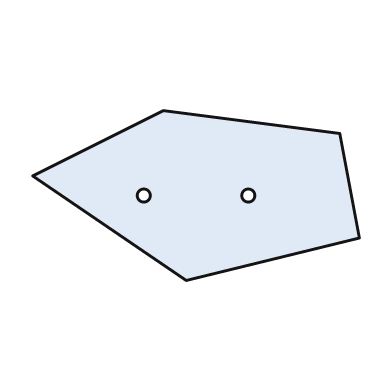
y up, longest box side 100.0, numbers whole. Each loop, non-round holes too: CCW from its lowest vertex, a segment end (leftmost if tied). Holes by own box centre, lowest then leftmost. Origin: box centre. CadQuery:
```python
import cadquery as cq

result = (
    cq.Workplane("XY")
    .moveTo(-3.0, -26.0)
    .lineTo(50.0, -13.0)
    .lineTo(44.0, 19.0)
    .lineTo(-10.0, 26.0)
    .lineTo(-50.0, 6.0)
    .close()
    .moveTo(-16.0, 0.0)
    .circle(2.0)
    .moveTo(16.0, 0.0)
    .circle(2.0)
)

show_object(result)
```